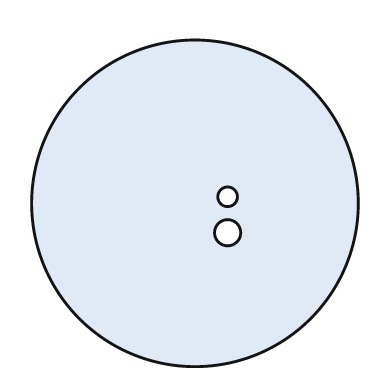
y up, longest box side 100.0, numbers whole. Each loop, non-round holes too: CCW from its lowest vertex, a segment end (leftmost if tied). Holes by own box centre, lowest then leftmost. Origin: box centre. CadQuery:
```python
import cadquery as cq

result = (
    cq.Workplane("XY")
    .moveTo(0.0, 0.0)
    .circle(50.0)
    .moveTo(10.0, -9.0)
    .circle(4.0)
    .moveTo(10.0, 2.0)
    .circle(3.0)
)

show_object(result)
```